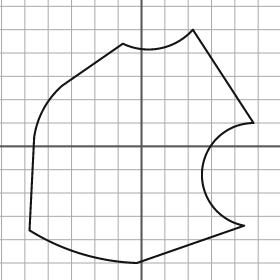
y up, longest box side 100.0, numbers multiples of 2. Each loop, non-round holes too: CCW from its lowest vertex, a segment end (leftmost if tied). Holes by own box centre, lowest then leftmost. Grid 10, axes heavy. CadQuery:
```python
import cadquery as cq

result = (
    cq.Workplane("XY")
    .moveTo(-2.0, -50.0)
    .lineTo(44.0, -34.0)
    .threePointArc((26.0, -10.0), (48.0, 10.0))
    .lineTo(22.0, 50.0)
    .threePointArc((8.0, 42.0), (-8.0, 44.0))
    .lineTo(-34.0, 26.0)
    .threePointArc((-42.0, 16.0), (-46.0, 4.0))
    .lineTo(-48.0, -36.0)
    .threePointArc((-26.0, -46.0), (-2.0, -50.0))
    .close()
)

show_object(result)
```